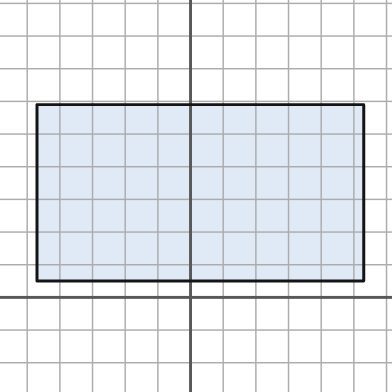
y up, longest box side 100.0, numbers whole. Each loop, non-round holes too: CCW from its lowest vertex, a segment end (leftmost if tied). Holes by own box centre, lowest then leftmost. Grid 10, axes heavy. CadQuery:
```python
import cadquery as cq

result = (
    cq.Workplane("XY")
    .moveTo(-47.0, 5.0)
    .lineTo(53.0, 5.0)
    .lineTo(53.0, 59.0)
    .lineTo(-47.0, 59.0)
    .close()
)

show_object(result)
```